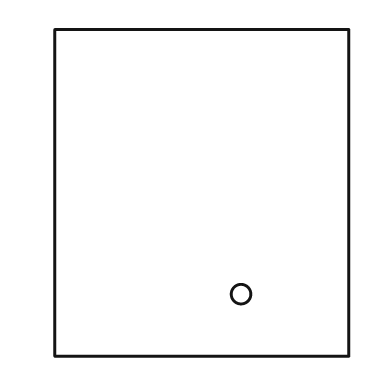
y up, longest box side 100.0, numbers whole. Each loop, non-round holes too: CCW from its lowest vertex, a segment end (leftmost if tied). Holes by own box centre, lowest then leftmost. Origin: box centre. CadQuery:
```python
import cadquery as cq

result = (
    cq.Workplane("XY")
    .moveTo(-45.0, -50.0)
    .lineTo(45.0, -50.0)
    .lineTo(45.0, 50.0)
    .lineTo(-45.0, 50.0)
    .close()
    .moveTo(12.0, -31.0)
    .circle(3.0)
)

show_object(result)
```